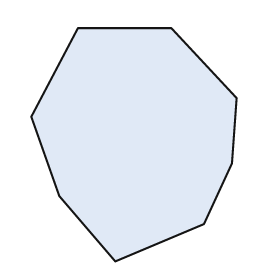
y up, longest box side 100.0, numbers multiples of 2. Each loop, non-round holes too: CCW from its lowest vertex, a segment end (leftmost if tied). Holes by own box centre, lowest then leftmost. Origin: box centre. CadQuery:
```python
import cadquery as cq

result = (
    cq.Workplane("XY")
    .moveTo(-8.0, -50.0)
    .lineTo(30.0, -34.0)
    .lineTo(42.0, -8.0)
    .lineTo(44.0, 20.0)
    .lineTo(16.0, 50.0)
    .lineTo(-24.0, 50.0)
    .lineTo(-44.0, 12.0)
    .lineTo(-32.0, -22.0)
    .close()
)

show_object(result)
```